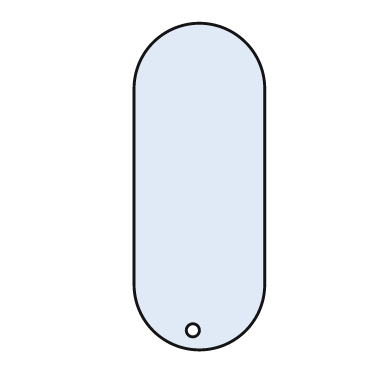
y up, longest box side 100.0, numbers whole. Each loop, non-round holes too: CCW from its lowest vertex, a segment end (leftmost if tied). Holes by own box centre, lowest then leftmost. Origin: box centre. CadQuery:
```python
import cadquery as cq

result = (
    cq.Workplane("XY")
    .moveTo(-20.0, -30.0)
    .threePointArc((0.0, -50.0), (20.0, -30.0))
    .lineTo(20.0, 30.0)
    .threePointArc((0.0, 50.0), (-20.0, 30.0))
    .close()
    .moveTo(-2.0, -44.0)
    .circle(2.0)
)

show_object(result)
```